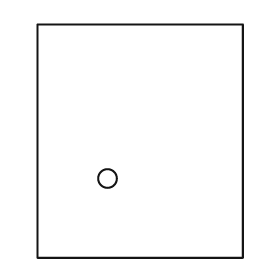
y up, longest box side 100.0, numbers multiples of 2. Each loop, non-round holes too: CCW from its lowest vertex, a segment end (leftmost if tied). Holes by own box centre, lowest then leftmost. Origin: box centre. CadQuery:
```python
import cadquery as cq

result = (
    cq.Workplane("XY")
    .moveTo(-44.0, -50.0)
    .lineTo(44.0, -50.0)
    .lineTo(44.0, 50.0)
    .lineTo(-44.0, 50.0)
    .close()
    .moveTo(-14.0, -16.0)
    .circle(4.0)
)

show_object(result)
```